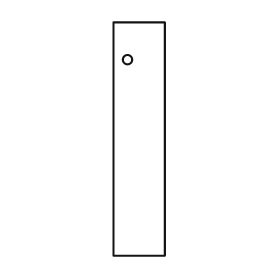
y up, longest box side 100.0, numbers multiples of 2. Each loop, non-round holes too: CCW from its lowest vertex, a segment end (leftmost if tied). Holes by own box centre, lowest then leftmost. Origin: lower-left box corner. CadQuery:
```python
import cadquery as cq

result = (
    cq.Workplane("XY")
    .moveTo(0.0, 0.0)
    .lineTo(22.0, 0.0)
    .lineTo(22.0, 100.0)
    .lineTo(0.0, 100.0)
    .close()
    .moveTo(6.0, 84.0)
    .circle(2.0)
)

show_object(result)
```